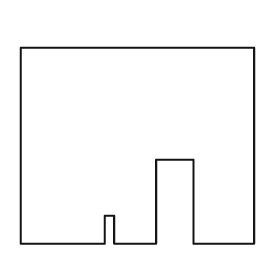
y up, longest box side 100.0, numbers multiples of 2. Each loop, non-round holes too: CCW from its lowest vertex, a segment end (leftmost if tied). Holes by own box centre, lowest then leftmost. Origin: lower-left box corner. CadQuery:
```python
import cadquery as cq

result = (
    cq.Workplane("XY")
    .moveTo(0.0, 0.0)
    .lineTo(36.0, 0.0)
    .lineTo(36.0, 12.0)
    .lineTo(40.0, 12.0)
    .lineTo(40.0, 0.0)
    .lineTo(58.0, 0.0)
    .lineTo(58.0, 36.0)
    .lineTo(74.0, 36.0)
    .lineTo(74.0, 0.0)
    .lineTo(100.0, 0.0)
    .lineTo(100.0, 84.0)
    .lineTo(0.0, 84.0)
    .close()
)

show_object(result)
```